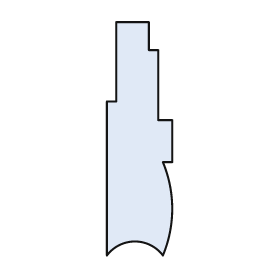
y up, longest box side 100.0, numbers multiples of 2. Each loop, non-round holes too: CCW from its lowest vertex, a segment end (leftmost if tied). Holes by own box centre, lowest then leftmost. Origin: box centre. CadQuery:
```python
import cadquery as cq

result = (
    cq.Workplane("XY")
    .moveTo(-14.0, -50.0)
    .threePointArc((-2.0, -44.0), (10.0, -50.0))
    .threePointArc((14.0, -30.0), (10.0, -10.0))
    .lineTo(14.0, -10.0)
    .lineTo(14.0, 8.0)
    .lineTo(8.0, 8.0)
    .lineTo(8.0, 38.0)
    .lineTo(4.0, 38.0)
    .lineTo(4.0, 50.0)
    .lineTo(-10.0, 50.0)
    .lineTo(-10.0, 16.0)
    .lineTo(-14.0, 16.0)
    .close()
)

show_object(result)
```